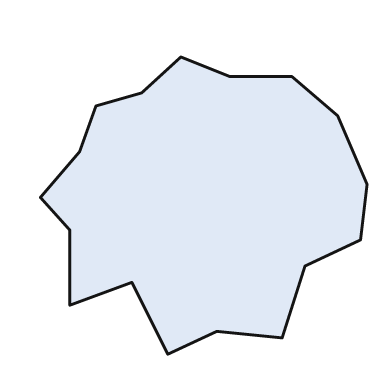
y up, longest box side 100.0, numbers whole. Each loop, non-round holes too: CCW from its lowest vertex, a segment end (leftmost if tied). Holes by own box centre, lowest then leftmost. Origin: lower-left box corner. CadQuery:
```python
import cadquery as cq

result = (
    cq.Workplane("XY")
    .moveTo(39.0, 0.0)
    .lineTo(54.0, 7.0)
    .lineTo(74.0, 5.0)
    .lineTo(81.0, 27.0)
    .lineTo(98.0, 35.0)
    .lineTo(100.0, 52.0)
    .lineTo(91.0, 73.0)
    .lineTo(77.0, 85.0)
    .lineTo(58.0, 85.0)
    .lineTo(43.0, 91.0)
    .lineTo(31.0, 80.0)
    .lineTo(17.0, 76.0)
    .lineTo(12.0, 62.0)
    .lineTo(0.0, 48.0)
    .lineTo(9.0, 38.0)
    .lineTo(9.0, 15.0)
    .lineTo(28.0, 22.0)
    .close()
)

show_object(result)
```